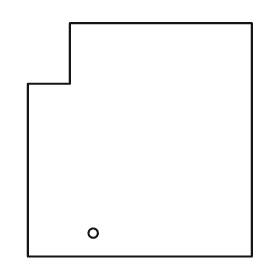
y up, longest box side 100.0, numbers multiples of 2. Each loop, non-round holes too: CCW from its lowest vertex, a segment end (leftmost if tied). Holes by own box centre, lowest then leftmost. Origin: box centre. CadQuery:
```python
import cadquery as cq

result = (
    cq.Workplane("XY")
    .moveTo(-48.0, -50.0)
    .lineTo(48.0, -50.0)
    .lineTo(48.0, 50.0)
    .lineTo(-30.0, 50.0)
    .lineTo(-30.0, 24.0)
    .lineTo(-48.0, 24.0)
    .close()
    .moveTo(-20.0, -40.0)
    .circle(2.0)
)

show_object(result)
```